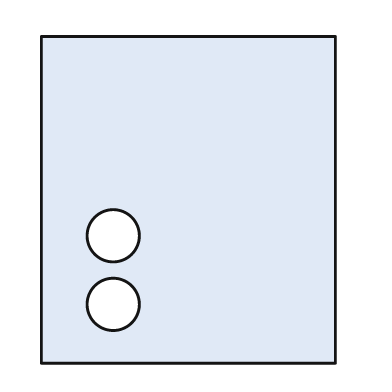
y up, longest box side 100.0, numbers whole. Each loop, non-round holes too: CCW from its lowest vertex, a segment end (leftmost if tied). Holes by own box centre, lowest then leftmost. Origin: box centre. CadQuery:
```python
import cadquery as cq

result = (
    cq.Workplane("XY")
    .moveTo(-45.0, -50.0)
    .lineTo(45.0, -50.0)
    .lineTo(45.0, 50.0)
    .lineTo(-45.0, 50.0)
    .close()
    .moveTo(-23.0, -32.0)
    .circle(8.0)
    .moveTo(-23.0, -11.0)
    .circle(8.0)
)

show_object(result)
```